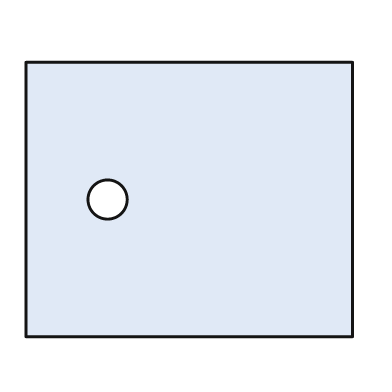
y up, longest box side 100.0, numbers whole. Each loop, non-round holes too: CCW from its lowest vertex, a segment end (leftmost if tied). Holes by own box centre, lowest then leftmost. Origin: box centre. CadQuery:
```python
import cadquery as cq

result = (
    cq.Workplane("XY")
    .moveTo(-50.0, -42.0)
    .lineTo(50.0, -42.0)
    .lineTo(50.0, 42.0)
    .lineTo(-50.0, 42.0)
    .close()
    .moveTo(-25.0, 0.0)
    .circle(6.0)
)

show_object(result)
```